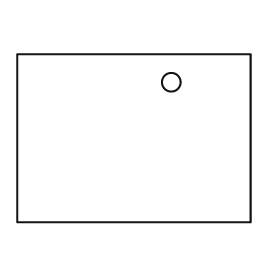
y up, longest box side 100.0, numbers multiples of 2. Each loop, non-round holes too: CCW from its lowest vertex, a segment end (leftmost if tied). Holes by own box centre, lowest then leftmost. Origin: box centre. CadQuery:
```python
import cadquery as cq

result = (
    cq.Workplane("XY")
    .moveTo(-50.0, -36.0)
    .lineTo(50.0, -36.0)
    .lineTo(50.0, 36.0)
    .lineTo(-50.0, 36.0)
    .close()
    .moveTo(16.0, 24.0)
    .circle(4.0)
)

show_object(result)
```